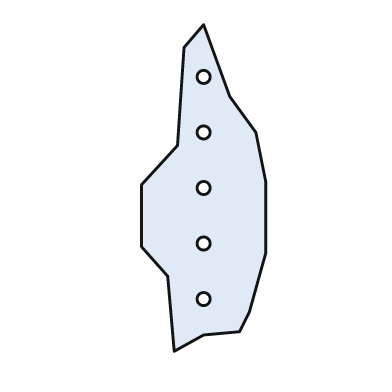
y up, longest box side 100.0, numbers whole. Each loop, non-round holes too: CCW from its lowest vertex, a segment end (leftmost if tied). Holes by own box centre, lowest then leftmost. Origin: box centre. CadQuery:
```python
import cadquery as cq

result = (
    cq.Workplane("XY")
    .moveTo(-9.0, -50.0)
    .lineTo(0.0, -45.0)
    .lineTo(11.0, -44.0)
    .lineTo(14.0, -38.0)
    .lineTo(19.0, -20.0)
    .lineTo(19.0, 2.0)
    .lineTo(16.0, 17.0)
    .lineTo(8.0, 28.0)
    .lineTo(0.0, 50.0)
    .lineTo(-6.0, 43.0)
    .lineTo(-8.0, 13.0)
    .lineTo(-19.0, 1.0)
    .lineTo(-19.0, -18.0)
    .lineTo(-11.0, -27.0)
    .close()
    .moveTo(0.0, -34.0)
    .circle(2.0)
    .moveTo(0.0, -17.0)
    .circle(2.0)
    .moveTo(0.0, 0.0)
    .circle(2.0)
    .moveTo(0.0, 17.0)
    .circle(2.0)
    .moveTo(0.0, 34.0)
    .circle(2.0)
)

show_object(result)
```